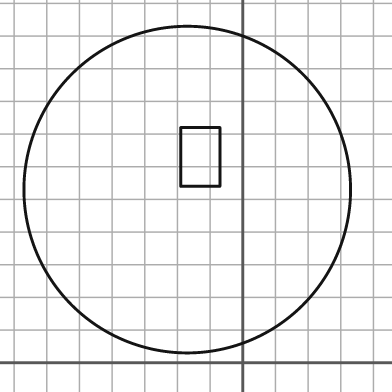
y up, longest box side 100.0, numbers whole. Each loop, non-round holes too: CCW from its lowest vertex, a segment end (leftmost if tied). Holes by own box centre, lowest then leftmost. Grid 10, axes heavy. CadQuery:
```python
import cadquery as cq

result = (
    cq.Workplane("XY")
    .moveTo(-17.0, 53.0)
    .circle(50.0)
    .moveTo(-19.0, 54.0)
    .lineTo(-7.0, 54.0)
    .lineTo(-7.0, 72.0)
    .lineTo(-19.0, 72.0)
    .close()
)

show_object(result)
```